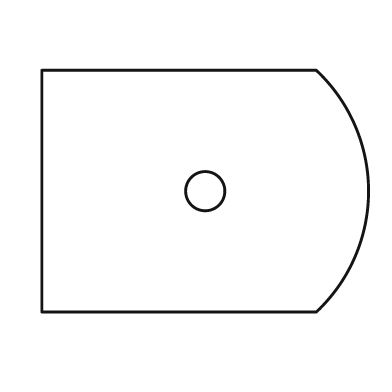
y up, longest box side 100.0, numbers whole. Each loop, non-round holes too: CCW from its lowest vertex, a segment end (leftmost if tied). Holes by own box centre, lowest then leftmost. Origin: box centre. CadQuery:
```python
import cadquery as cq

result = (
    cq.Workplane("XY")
    .moveTo(-50.0, -37.0)
    .lineTo(34.0, -37.0)
    .threePointArc((50.0, 0.0), (34.0, 37.0))
    .lineTo(-50.0, 37.0)
    .close()
    .moveTo(0.0, 0.0)
    .circle(6.0)
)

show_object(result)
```